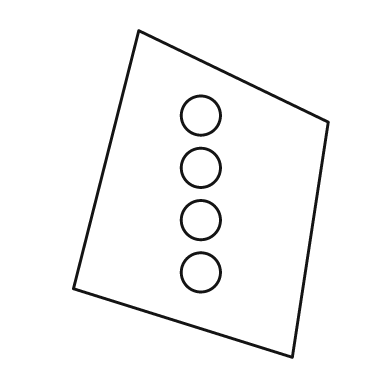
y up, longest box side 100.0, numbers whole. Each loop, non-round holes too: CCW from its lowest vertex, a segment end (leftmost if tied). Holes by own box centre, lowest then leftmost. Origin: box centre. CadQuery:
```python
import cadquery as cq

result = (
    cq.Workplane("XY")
    .moveTo(28.0, -50.0)
    .lineTo(39.0, 22.0)
    .lineTo(-19.0, 50.0)
    .lineTo(-39.0, -29.0)
    .close()
    .moveTo(0.0, -24.0)
    .circle(6.0)
    .moveTo(0.0, -8.0)
    .circle(6.0)
    .moveTo(0.0, 8.0)
    .circle(6.0)
    .moveTo(0.0, 24.0)
    .circle(6.0)
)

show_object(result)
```